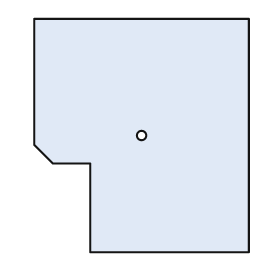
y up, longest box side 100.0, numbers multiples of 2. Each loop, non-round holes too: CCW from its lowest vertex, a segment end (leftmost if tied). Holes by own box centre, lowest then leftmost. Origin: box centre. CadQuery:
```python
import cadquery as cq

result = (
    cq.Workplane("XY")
    .moveTo(-22.0, -50.0)
    .lineTo(46.0, -50.0)
    .lineTo(46.0, 50.0)
    .lineTo(-46.0, 50.0)
    .lineTo(-46.0, -4.0)
    .lineTo(-38.0, -12.0)
    .lineTo(-22.0, -12.0)
    .close()
    .moveTo(0.0, 0.0)
    .circle(2.0)
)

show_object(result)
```